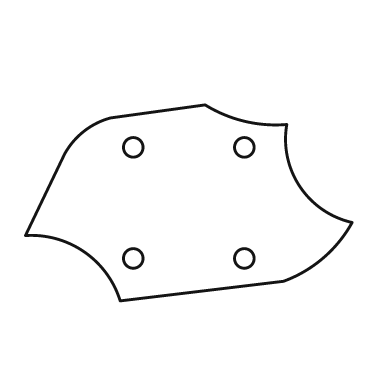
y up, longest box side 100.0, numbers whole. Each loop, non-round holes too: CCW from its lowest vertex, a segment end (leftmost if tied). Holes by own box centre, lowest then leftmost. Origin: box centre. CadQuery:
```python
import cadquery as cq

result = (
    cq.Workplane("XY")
    .moveTo(-21.0, -30.0)
    .lineTo(29.0, -24.0)
    .threePointArc((41.0, -17.0), (50.0, -6.0))
    .threePointArc((34.0, 5.0), (30.0, 24.0))
    .threePointArc((17.0, 25.0), (5.0, 30.0))
    .lineTo(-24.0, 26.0)
    .threePointArc((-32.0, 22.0), (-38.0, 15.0))
    .lineTo(-50.0, -10.0)
    .threePointArc((-32.0, -15.0), (-21.0, -30.0))
    .close()
    .moveTo(-17.0, -17.0)
    .circle(3.0)
    .moveTo(17.0, -17.0)
    .circle(3.0)
    .moveTo(-17.0, 17.0)
    .circle(3.0)
    .moveTo(17.0, 17.0)
    .circle(3.0)
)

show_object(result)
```